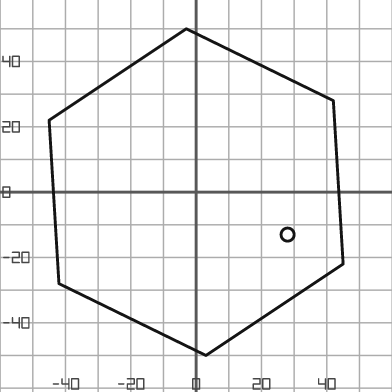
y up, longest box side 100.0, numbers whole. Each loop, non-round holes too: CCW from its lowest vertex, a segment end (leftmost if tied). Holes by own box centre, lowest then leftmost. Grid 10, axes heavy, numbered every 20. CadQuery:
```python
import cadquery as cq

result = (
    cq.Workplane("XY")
    .moveTo(3.0, -50.0)
    .lineTo(45.0, -22.0)
    .lineTo(42.0, 28.0)
    .lineTo(-3.0, 50.0)
    .lineTo(-45.0, 22.0)
    .lineTo(-42.0, -28.0)
    .close()
    .moveTo(28.0, -13.0)
    .circle(2.0)
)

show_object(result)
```